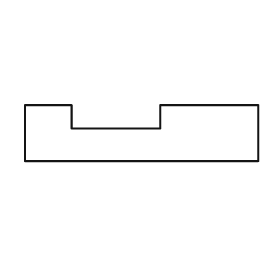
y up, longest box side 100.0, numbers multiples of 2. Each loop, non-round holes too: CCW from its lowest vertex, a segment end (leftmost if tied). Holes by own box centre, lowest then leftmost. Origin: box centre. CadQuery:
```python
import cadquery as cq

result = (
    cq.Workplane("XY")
    .moveTo(-50.0, -12.0)
    .lineTo(50.0, -12.0)
    .lineTo(50.0, 12.0)
    .lineTo(8.0, 12.0)
    .lineTo(8.0, 2.0)
    .lineTo(-30.0, 2.0)
    .lineTo(-30.0, 12.0)
    .lineTo(-50.0, 12.0)
    .close()
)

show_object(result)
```